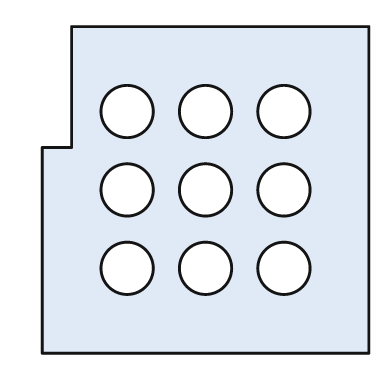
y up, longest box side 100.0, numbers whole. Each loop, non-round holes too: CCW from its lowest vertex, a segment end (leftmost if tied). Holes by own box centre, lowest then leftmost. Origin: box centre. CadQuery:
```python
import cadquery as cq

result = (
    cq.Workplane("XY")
    .moveTo(-50.0, -50.0)
    .lineTo(50.0, -50.0)
    .lineTo(50.0, 50.0)
    .lineTo(-41.0, 50.0)
    .lineTo(-41.0, 13.0)
    .lineTo(-50.0, 13.0)
    .close()
    .moveTo(-24.0, -24.0)
    .circle(8.0)
    .moveTo(0.0, -24.0)
    .circle(8.0)
    .moveTo(24.0, -24.0)
    .circle(8.0)
    .moveTo(-24.0, 0.0)
    .circle(8.0)
    .moveTo(0.0, 0.0)
    .circle(8.0)
    .moveTo(24.0, 0.0)
    .circle(8.0)
    .moveTo(-24.0, 24.0)
    .circle(8.0)
    .moveTo(0.0, 24.0)
    .circle(8.0)
    .moveTo(24.0, 24.0)
    .circle(8.0)
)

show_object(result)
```